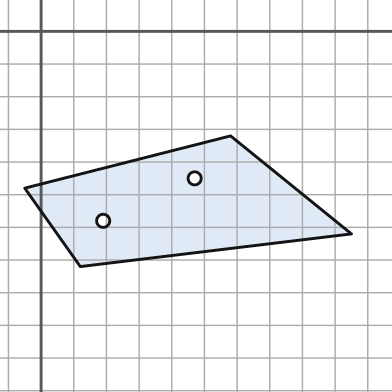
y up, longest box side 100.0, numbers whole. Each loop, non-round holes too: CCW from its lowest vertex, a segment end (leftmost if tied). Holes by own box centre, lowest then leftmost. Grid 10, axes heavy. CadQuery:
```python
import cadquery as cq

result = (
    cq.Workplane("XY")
    .moveTo(12.0, -72.0)
    .lineTo(95.0, -62.0)
    .lineTo(58.0, -32.0)
    .lineTo(-5.0, -48.0)
    .close()
    .moveTo(19.0, -58.0)
    .circle(2.0)
    .moveTo(47.0, -45.0)
    .circle(2.0)
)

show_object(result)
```